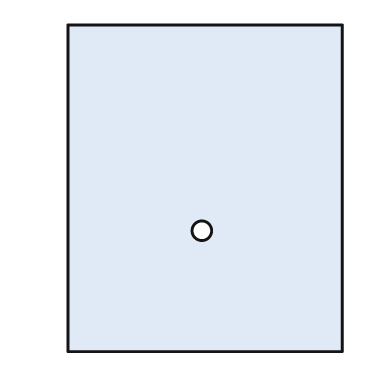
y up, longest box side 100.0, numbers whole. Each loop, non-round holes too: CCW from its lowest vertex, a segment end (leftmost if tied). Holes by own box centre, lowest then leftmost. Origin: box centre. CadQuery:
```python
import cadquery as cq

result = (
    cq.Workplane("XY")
    .moveTo(-42.0, -50.0)
    .lineTo(42.0, -50.0)
    .lineTo(42.0, 50.0)
    .lineTo(-42.0, 50.0)
    .close()
    .moveTo(-1.0, -13.0)
    .circle(3.0)
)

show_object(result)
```